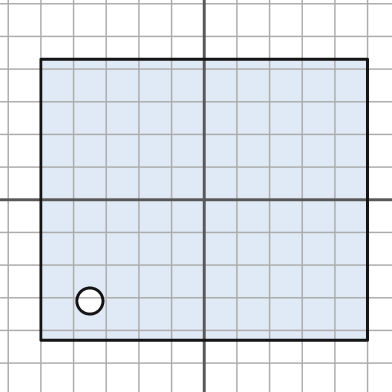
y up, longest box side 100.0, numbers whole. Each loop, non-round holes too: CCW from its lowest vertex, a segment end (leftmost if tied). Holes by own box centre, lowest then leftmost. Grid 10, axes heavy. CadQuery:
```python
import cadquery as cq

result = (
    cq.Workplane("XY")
    .moveTo(-50.0, -43.0)
    .lineTo(50.0, -43.0)
    .lineTo(50.0, 43.0)
    .lineTo(-50.0, 43.0)
    .close()
    .moveTo(-35.0, -31.0)
    .circle(4.0)
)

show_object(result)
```